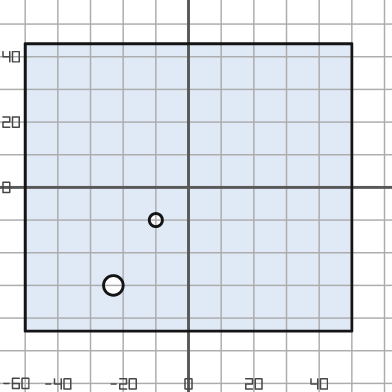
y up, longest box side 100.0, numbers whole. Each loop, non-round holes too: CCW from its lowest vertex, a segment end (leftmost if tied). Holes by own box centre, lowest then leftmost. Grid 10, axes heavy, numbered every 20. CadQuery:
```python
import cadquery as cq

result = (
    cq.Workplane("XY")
    .moveTo(-50.0, -44.0)
    .lineTo(50.0, -44.0)
    .lineTo(50.0, 44.0)
    .lineTo(-50.0, 44.0)
    .close()
    .moveTo(-23.0, -30.0)
    .circle(3.0)
    .moveTo(-10.0, -10.0)
    .circle(2.0)
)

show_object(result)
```